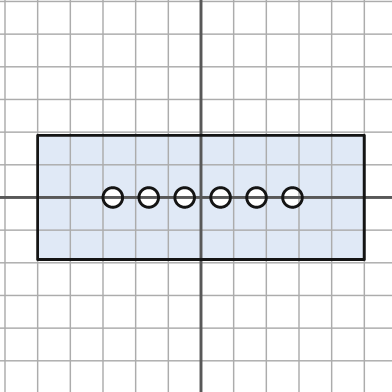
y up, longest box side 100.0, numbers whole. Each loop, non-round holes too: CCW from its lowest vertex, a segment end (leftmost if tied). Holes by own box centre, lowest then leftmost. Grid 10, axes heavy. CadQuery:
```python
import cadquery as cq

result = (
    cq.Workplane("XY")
    .moveTo(-50.0, -19.0)
    .lineTo(50.0, -19.0)
    .lineTo(50.0, 19.0)
    .lineTo(-50.0, 19.0)
    .close()
    .moveTo(-27.0, 0.0)
    .circle(3.0)
    .moveTo(-16.0, 0.0)
    .circle(3.0)
    .moveTo(-5.0, 0.0)
    .circle(3.0)
    .moveTo(6.0, 0.0)
    .circle(3.0)
    .moveTo(17.0, 0.0)
    .circle(3.0)
    .moveTo(28.0, 0.0)
    .circle(3.0)
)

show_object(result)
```